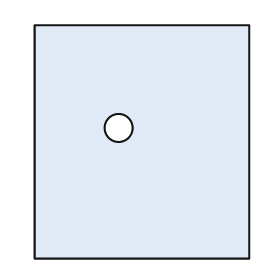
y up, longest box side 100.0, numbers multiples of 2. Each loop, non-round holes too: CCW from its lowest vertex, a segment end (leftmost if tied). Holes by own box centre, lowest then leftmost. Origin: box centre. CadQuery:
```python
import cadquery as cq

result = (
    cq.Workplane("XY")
    .moveTo(-46.0, -50.0)
    .lineTo(46.0, -50.0)
    .lineTo(46.0, 50.0)
    .lineTo(-46.0, 50.0)
    .close()
    .moveTo(-10.0, 6.0)
    .circle(6.0)
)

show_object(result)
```